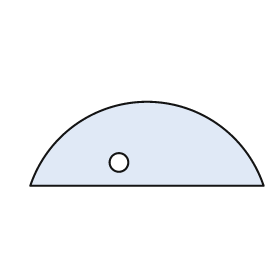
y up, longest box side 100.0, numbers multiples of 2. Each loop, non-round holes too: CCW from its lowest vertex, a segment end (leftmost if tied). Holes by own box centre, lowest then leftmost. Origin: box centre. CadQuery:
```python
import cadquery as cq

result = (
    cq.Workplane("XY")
    .moveTo(-50.0, -18.0)
    .lineTo(50.0, -18.0)
    .threePointArc((0.0, 18.0), (-50.0, -18.0))
    .close()
    .moveTo(-12.0, -8.0)
    .circle(4.0)
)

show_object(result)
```